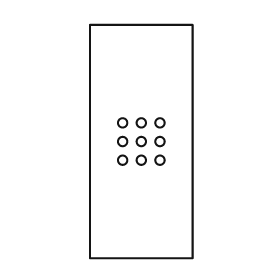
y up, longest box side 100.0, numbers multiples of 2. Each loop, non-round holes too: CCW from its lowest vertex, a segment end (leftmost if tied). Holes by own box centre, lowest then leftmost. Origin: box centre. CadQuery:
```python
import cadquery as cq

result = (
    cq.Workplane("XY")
    .moveTo(-22.0, -50.0)
    .lineTo(22.0, -50.0)
    .lineTo(22.0, 50.0)
    .lineTo(-22.0, 50.0)
    .close()
    .moveTo(-8.0, -8.0)
    .circle(2.0)
    .moveTo(0.0, -8.0)
    .circle(2.0)
    .moveTo(8.0, -8.0)
    .circle(2.0)
    .moveTo(-8.0, 0.0)
    .circle(2.0)
    .moveTo(0.0, 0.0)
    .circle(2.0)
    .moveTo(8.0, 0.0)
    .circle(2.0)
    .moveTo(-8.0, 8.0)
    .circle(2.0)
    .moveTo(0.0, 8.0)
    .circle(2.0)
    .moveTo(8.0, 8.0)
    .circle(2.0)
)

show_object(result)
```